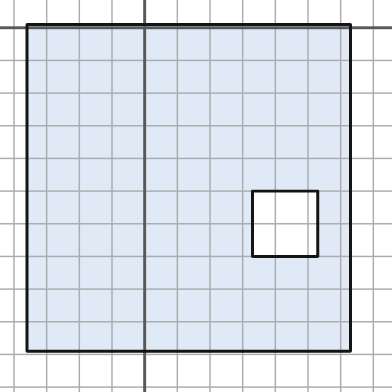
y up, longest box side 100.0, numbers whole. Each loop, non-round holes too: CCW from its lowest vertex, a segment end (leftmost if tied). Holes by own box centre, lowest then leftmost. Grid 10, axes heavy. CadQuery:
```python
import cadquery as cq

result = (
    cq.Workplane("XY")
    .moveTo(-36.0, -99.0)
    .lineTo(63.0, -99.0)
    .lineTo(63.0, 1.0)
    .lineTo(-36.0, 1.0)
    .close()
    .moveTo(33.0, -70.0)
    .lineTo(53.0, -70.0)
    .lineTo(53.0, -50.0)
    .lineTo(33.0, -50.0)
    .close()
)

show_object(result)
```